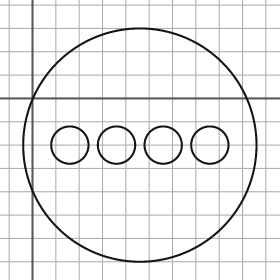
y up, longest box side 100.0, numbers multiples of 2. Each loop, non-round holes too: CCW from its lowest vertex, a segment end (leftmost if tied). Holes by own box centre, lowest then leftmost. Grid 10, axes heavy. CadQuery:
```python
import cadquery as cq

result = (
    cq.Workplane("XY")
    .moveTo(46.0, -20.0)
    .circle(50.0)
    .moveTo(16.0, -20.0)
    .circle(8.0)
    .moveTo(36.0, -20.0)
    .circle(8.0)
    .moveTo(56.0, -20.0)
    .circle(8.0)
    .moveTo(76.0, -20.0)
    .circle(8.0)
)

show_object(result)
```